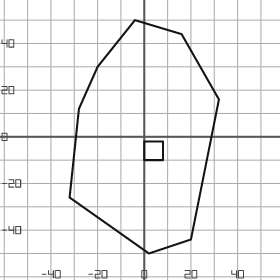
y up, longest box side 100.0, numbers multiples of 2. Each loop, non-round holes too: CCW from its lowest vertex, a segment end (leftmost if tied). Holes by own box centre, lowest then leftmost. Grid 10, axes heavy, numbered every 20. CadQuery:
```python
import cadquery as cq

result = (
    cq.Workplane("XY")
    .moveTo(2.0, -50.0)
    .lineTo(20.0, -44.0)
    .lineTo(32.0, 16.0)
    .lineTo(16.0, 44.0)
    .lineTo(-4.0, 50.0)
    .lineTo(-20.0, 30.0)
    .lineTo(-28.0, 12.0)
    .lineTo(-32.0, -26.0)
    .close()
    .moveTo(0.0, -10.0)
    .lineTo(8.0, -10.0)
    .lineTo(8.0, -2.0)
    .lineTo(0.0, -2.0)
    .close()
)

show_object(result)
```